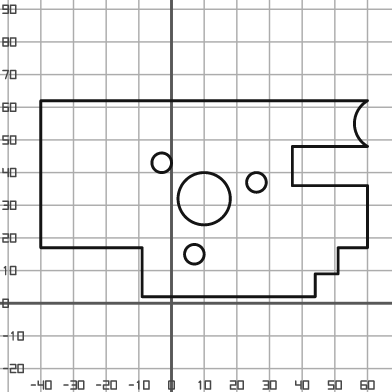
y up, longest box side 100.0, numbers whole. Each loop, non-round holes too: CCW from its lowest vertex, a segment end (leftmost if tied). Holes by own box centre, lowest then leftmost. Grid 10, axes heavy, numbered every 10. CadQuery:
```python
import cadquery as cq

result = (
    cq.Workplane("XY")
    .moveTo(-9.0, 2.0)
    .lineTo(44.0, 2.0)
    .lineTo(44.0, 9.0)
    .lineTo(51.0, 9.0)
    .lineTo(51.0, 17.0)
    .lineTo(60.0, 17.0)
    .lineTo(60.0, 36.0)
    .lineTo(37.0, 36.0)
    .lineTo(37.0, 48.0)
    .lineTo(60.0, 48.0)
    .threePointArc((56.0, 55.0), (60.0, 62.0))
    .lineTo(-40.0, 62.0)
    .lineTo(-40.0, 17.0)
    .lineTo(-9.0, 17.0)
    .close()
    .moveTo(7.0, 15.0)
    .circle(3.0)
    .moveTo(10.0, 32.0)
    .circle(8.0)
    .moveTo(26.0, 37.0)
    .circle(3.0)
    .moveTo(-3.0, 43.0)
    .circle(3.0)
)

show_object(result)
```